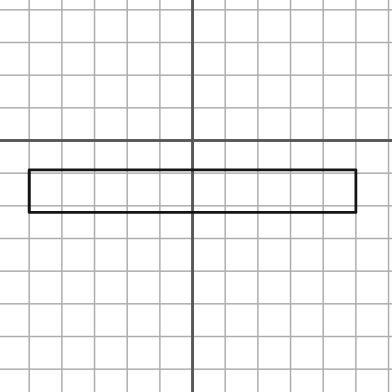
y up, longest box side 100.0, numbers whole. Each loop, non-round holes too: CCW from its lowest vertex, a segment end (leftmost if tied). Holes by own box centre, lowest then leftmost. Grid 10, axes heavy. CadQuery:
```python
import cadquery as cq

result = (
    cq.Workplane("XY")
    .moveTo(-50.0, -22.0)
    .lineTo(50.0, -22.0)
    .lineTo(50.0, -9.0)
    .lineTo(-50.0, -9.0)
    .close()
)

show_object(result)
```